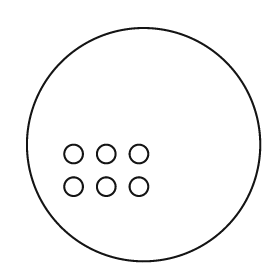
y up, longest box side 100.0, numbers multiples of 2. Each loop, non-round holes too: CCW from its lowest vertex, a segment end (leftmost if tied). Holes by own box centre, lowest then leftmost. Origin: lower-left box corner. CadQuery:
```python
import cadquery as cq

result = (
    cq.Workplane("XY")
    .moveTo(50.0, 50.0)
    .circle(50.0)
    .moveTo(20.0, 32.0)
    .circle(4.0)
    .moveTo(34.0, 32.0)
    .circle(4.0)
    .moveTo(48.0, 32.0)
    .circle(4.0)
    .moveTo(20.0, 46.0)
    .circle(4.0)
    .moveTo(34.0, 46.0)
    .circle(4.0)
    .moveTo(48.0, 46.0)
    .circle(4.0)
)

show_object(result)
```